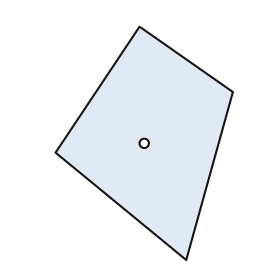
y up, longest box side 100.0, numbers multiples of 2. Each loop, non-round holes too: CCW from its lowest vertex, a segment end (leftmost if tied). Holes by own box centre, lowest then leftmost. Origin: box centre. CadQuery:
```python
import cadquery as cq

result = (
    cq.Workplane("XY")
    .moveTo(18.0, -50.0)
    .lineTo(38.0, 22.0)
    .lineTo(-2.0, 50.0)
    .lineTo(-38.0, -4.0)
    .close()
    .moveTo(0.0, 0.0)
    .circle(2.0)
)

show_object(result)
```